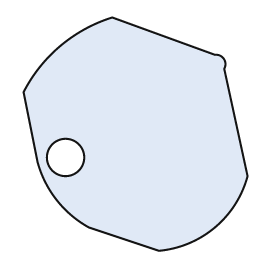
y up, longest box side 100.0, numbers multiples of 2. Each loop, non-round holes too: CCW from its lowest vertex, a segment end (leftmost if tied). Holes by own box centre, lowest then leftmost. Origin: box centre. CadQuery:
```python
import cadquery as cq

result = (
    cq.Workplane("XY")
    .moveTo(10.0, -50.0)
    .threePointArc((34.0, -40.0), (48.0, -18.0))
    .lineTo(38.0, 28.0)
    .threePointArc((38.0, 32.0), (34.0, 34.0))
    .lineTo(-10.0, 50.0)
    .threePointArc((-32.0, 38.0), (-48.0, 18.0))
    .lineTo(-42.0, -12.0)
    .threePointArc((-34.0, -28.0), (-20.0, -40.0))
    .close()
    .moveTo(-30.0, -10.0)
    .circle(8.0)
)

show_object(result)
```